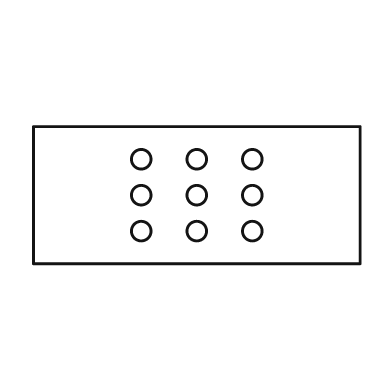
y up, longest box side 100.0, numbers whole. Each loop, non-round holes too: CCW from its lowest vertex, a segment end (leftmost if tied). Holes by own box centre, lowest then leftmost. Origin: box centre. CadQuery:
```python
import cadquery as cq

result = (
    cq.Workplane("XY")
    .moveTo(-50.0, -21.0)
    .lineTo(50.0, -21.0)
    .lineTo(50.0, 21.0)
    .lineTo(-50.0, 21.0)
    .close()
    .moveTo(-17.0, -11.0)
    .circle(3.0)
    .moveTo(0.0, -11.0)
    .circle(3.0)
    .moveTo(17.0, -11.0)
    .circle(3.0)
    .moveTo(-17.0, 0.0)
    .circle(3.0)
    .moveTo(0.0, 0.0)
    .circle(3.0)
    .moveTo(17.0, 0.0)
    .circle(3.0)
    .moveTo(-17.0, 11.0)
    .circle(3.0)
    .moveTo(0.0, 11.0)
    .circle(3.0)
    .moveTo(17.0, 11.0)
    .circle(3.0)
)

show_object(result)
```